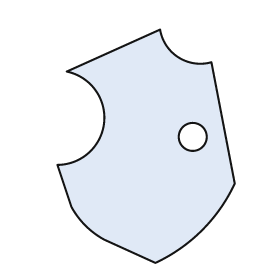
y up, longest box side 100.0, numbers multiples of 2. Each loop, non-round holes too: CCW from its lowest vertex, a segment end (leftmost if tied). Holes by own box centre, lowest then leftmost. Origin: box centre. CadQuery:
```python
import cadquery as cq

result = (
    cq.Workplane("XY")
    .moveTo(4.0, -50.0)
    .threePointArc((24.0, -36.0), (38.0, -16.0))
    .lineTo(28.0, 36.0)
    .threePointArc((14.0, 38.0), (6.0, 50.0))
    .lineTo(-34.0, 32.0)
    .threePointArc((-18.0, 10.0), (-38.0, -8.0))
    .lineTo(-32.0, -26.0)
    .threePointArc((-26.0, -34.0), (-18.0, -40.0))
    .close()
    .moveTo(20.0, 4.0)
    .circle(6.0)
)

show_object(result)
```